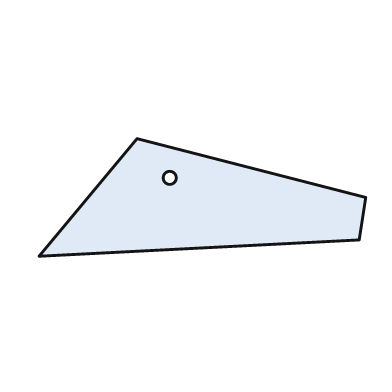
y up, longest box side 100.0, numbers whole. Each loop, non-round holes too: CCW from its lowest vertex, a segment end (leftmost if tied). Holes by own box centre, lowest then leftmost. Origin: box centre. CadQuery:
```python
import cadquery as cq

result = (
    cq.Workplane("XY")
    .moveTo(-50.0, -18.0)
    .lineTo(48.0, -13.0)
    .lineTo(50.0, 0.0)
    .lineTo(-20.0, 18.0)
    .close()
    .moveTo(-10.0, 6.0)
    .circle(2.0)
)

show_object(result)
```